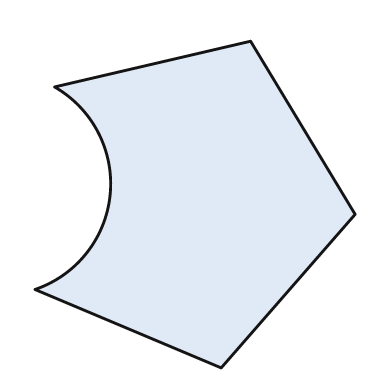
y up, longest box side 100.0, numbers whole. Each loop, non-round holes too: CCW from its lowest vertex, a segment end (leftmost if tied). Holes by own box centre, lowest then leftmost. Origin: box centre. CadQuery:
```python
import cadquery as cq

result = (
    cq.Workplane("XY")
    .moveTo(8.0, -50.0)
    .lineTo(49.0, -3.0)
    .lineTo(17.0, 50.0)
    .lineTo(-43.0, 36.0)
    .threePointArc((-26.0, 3.0), (-49.0, -26.0))
    .close()
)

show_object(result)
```